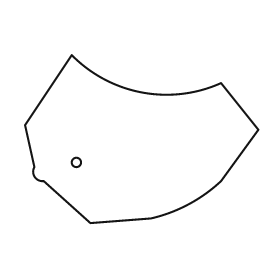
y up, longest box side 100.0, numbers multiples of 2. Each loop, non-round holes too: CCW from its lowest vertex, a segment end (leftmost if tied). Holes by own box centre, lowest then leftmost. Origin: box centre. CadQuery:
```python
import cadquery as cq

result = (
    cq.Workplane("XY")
    .moveTo(-22.0, -36.0)
    .lineTo(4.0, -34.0)
    .threePointArc((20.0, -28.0), (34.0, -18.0))
    .lineTo(50.0, 4.0)
    .lineTo(34.0, 24.0)
    .threePointArc((0.0, 20.0), (-30.0, 36.0))
    .lineTo(-50.0, 6.0)
    .lineTo(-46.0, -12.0)
    .threePointArc((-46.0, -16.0), (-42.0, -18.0))
    .close()
    .moveTo(-28.0, -10.0)
    .circle(2.0)
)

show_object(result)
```